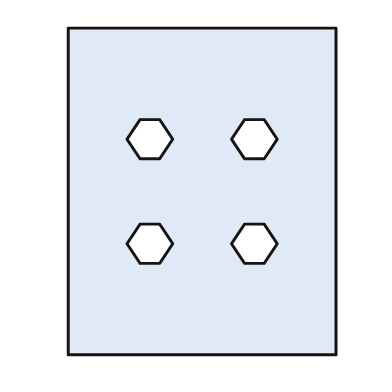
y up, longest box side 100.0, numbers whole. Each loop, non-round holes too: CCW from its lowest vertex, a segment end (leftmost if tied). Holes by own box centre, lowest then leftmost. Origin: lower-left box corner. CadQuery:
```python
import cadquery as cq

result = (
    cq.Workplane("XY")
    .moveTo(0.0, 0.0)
    .lineTo(82.0, 0.0)
    .lineTo(82.0, 100.0)
    .lineTo(0.0, 100.0)
    .close()
    .moveTo(22.0, 28.0)
    .lineTo(28.0, 28.0)
    .lineTo(32.0, 34.0)
    .lineTo(28.0, 40.0)
    .lineTo(22.0, 40.0)
    .lineTo(18.0, 34.0)
    .close()
    .moveTo(54.0, 28.0)
    .lineTo(60.0, 28.0)
    .lineTo(64.0, 34.0)
    .lineTo(60.0, 40.0)
    .lineTo(54.0, 40.0)
    .lineTo(50.0, 34.0)
    .close()
    .moveTo(22.0, 60.0)
    .lineTo(28.0, 60.0)
    .lineTo(32.0, 66.0)
    .lineTo(28.0, 72.0)
    .lineTo(22.0, 72.0)
    .lineTo(18.0, 66.0)
    .close()
    .moveTo(54.0, 60.0)
    .lineTo(60.0, 60.0)
    .lineTo(64.0, 66.0)
    .lineTo(60.0, 72.0)
    .lineTo(54.0, 72.0)
    .lineTo(50.0, 66.0)
    .close()
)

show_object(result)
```